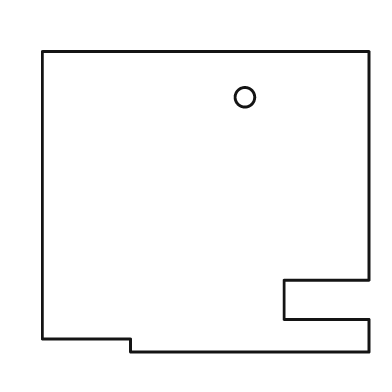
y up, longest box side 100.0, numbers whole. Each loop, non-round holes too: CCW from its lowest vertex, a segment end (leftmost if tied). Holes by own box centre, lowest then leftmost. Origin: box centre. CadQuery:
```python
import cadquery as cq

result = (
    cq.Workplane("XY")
    .moveTo(-23.0, -46.0)
    .lineTo(50.0, -46.0)
    .lineTo(50.0, -36.0)
    .lineTo(24.0, -36.0)
    .lineTo(24.0, -24.0)
    .lineTo(50.0, -24.0)
    .lineTo(50.0, 46.0)
    .lineTo(-50.0, 46.0)
    .lineTo(-50.0, -42.0)
    .lineTo(-23.0, -42.0)
    .close()
    .moveTo(12.0, 32.0)
    .circle(3.0)
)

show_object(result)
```